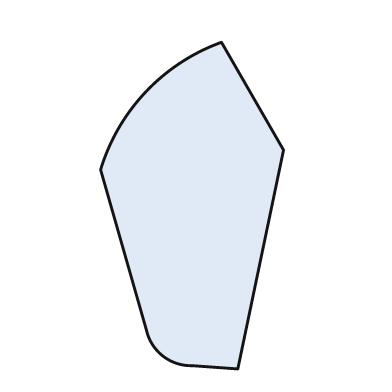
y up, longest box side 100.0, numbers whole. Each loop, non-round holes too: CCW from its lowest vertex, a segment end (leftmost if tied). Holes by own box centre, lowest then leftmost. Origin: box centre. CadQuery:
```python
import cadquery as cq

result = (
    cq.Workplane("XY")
    .moveTo(14.0, -50.0)
    .lineTo(28.0, 17.0)
    .lineTo(9.0, 50.0)
    .threePointArc((-14.0, 35.0), (-28.0, 11.0))
    .lineTo(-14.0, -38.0)
    .threePointArc((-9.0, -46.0), (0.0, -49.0))
    .close()
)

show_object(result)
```